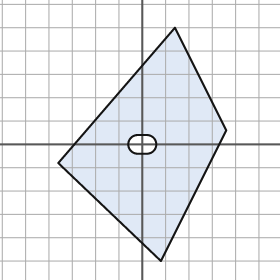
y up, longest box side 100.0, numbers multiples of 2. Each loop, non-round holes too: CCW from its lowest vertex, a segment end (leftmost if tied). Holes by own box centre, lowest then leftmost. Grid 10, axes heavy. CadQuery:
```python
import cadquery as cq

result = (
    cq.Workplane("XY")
    .moveTo(8.0, -50.0)
    .lineTo(36.0, 6.0)
    .lineTo(14.0, 50.0)
    .lineTo(-36.0, -8.0)
    .close()
    .moveTo(-2.0, -4.0)
    .lineTo(2.0, -4.0)
    .threePointArc((6.0, 0.0), (2.0, 4.0))
    .lineTo(-2.0, 4.0)
    .threePointArc((-6.0, 0.0), (-2.0, -4.0))
    .close()
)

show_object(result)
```